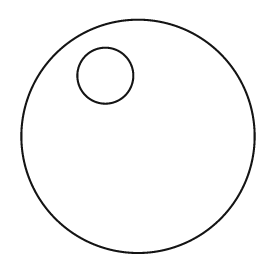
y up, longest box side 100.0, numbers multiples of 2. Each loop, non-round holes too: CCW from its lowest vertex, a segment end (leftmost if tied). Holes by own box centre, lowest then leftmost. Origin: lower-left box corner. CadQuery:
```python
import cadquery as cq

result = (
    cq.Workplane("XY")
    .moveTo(50.0, 50.0)
    .circle(50.0)
    .moveTo(36.0, 76.0)
    .circle(12.0)
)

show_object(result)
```